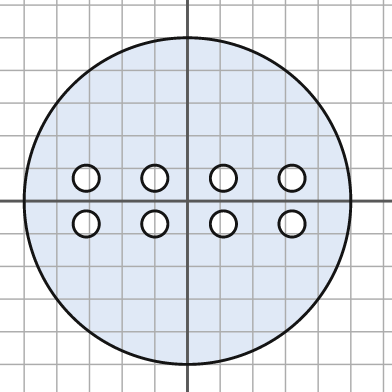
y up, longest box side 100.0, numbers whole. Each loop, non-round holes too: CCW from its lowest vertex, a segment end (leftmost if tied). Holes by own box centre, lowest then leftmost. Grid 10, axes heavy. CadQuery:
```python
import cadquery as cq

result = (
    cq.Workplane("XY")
    .moveTo(0.0, 0.0)
    .circle(50.0)
    .moveTo(-31.0, -7.0)
    .circle(4.0)
    .moveTo(-10.0, -7.0)
    .circle(4.0)
    .moveTo(11.0, -7.0)
    .circle(4.0)
    .moveTo(32.0, -7.0)
    .circle(4.0)
    .moveTo(-31.0, 7.0)
    .circle(4.0)
    .moveTo(-10.0, 7.0)
    .circle(4.0)
    .moveTo(11.0, 7.0)
    .circle(4.0)
    .moveTo(32.0, 7.0)
    .circle(4.0)
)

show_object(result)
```